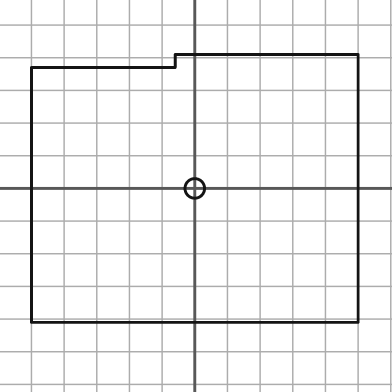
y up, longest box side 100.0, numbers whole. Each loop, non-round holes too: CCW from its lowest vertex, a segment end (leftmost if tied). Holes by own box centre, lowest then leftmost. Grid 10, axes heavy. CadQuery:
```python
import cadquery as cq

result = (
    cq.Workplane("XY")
    .moveTo(-50.0, -41.0)
    .lineTo(50.0, -41.0)
    .lineTo(50.0, 41.0)
    .lineTo(-6.0, 41.0)
    .lineTo(-6.0, 37.0)
    .lineTo(-50.0, 37.0)
    .close()
    .moveTo(0.0, 0.0)
    .circle(3.0)
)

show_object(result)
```